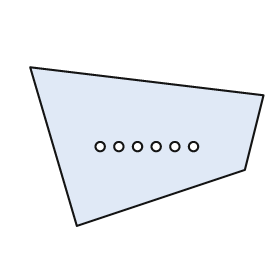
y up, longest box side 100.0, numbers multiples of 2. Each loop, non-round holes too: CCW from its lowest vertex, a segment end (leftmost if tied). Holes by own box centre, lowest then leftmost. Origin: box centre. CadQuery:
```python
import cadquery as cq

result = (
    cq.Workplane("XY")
    .moveTo(-30.0, -34.0)
    .lineTo(42.0, -10.0)
    .lineTo(50.0, 22.0)
    .lineTo(-50.0, 34.0)
    .close()
    .moveTo(-20.0, 0.0)
    .circle(2.0)
    .moveTo(-12.0, 0.0)
    .circle(2.0)
    .moveTo(-4.0, 0.0)
    .circle(2.0)
    .moveTo(4.0, 0.0)
    .circle(2.0)
    .moveTo(12.0, 0.0)
    .circle(2.0)
    .moveTo(20.0, 0.0)
    .circle(2.0)
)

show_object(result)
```